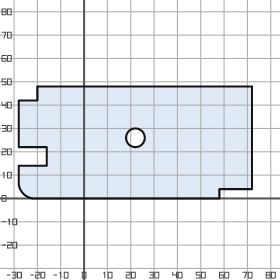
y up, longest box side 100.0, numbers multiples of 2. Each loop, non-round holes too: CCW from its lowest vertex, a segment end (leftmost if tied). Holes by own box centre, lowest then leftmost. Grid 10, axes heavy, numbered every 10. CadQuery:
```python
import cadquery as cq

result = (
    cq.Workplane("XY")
    .moveTo(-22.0, 0.0)
    .lineTo(58.0, 0.0)
    .lineTo(58.0, 4.0)
    .lineTo(72.0, 4.0)
    .lineTo(72.0, 48.0)
    .lineTo(-20.0, 48.0)
    .lineTo(-20.0, 42.0)
    .lineTo(-28.0, 42.0)
    .lineTo(-28.0, 22.0)
    .lineTo(-16.0, 22.0)
    .lineTo(-16.0, 14.0)
    .lineTo(-28.0, 14.0)
    .lineTo(-28.0, 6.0)
    .threePointArc((-26.0, 2.0), (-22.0, 0.0))
    .close()
    .moveTo(22.0, 26.0)
    .circle(4.0)
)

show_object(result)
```